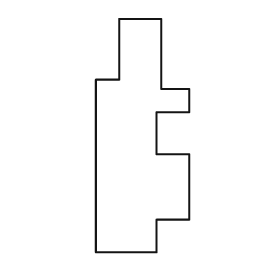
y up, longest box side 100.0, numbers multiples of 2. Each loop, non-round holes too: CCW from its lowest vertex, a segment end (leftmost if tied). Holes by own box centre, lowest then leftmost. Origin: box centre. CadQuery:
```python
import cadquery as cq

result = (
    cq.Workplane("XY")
    .moveTo(-20.0, -50.0)
    .lineTo(6.0, -50.0)
    .lineTo(6.0, -36.0)
    .lineTo(20.0, -36.0)
    .lineTo(20.0, -8.0)
    .lineTo(6.0, -8.0)
    .lineTo(6.0, 10.0)
    .lineTo(20.0, 10.0)
    .lineTo(20.0, 20.0)
    .lineTo(8.0, 20.0)
    .lineTo(8.0, 50.0)
    .lineTo(-10.0, 50.0)
    .lineTo(-10.0, 24.0)
    .lineTo(-20.0, 24.0)
    .close()
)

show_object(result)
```